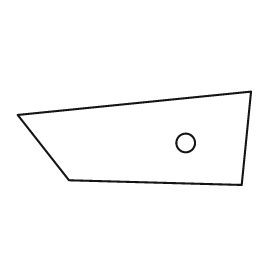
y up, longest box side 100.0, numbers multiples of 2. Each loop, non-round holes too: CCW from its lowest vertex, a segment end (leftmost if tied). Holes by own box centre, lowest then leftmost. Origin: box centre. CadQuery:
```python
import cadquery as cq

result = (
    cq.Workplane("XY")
    .moveTo(46.0, -20.0)
    .lineTo(50.0, 20.0)
    .lineTo(-50.0, 10.0)
    .lineTo(-28.0, -18.0)
    .close()
    .moveTo(22.0, -2.0)
    .circle(4.0)
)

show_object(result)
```